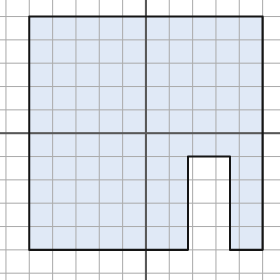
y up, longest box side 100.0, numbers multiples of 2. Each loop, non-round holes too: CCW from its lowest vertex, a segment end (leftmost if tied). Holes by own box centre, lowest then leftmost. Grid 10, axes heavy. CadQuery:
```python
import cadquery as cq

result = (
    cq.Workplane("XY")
    .moveTo(-50.0, -50.0)
    .lineTo(18.0, -50.0)
    .lineTo(18.0, -10.0)
    .lineTo(36.0, -10.0)
    .lineTo(36.0, -50.0)
    .lineTo(50.0, -50.0)
    .lineTo(50.0, 50.0)
    .lineTo(-50.0, 50.0)
    .close()
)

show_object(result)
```